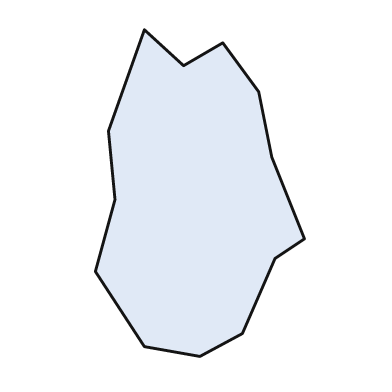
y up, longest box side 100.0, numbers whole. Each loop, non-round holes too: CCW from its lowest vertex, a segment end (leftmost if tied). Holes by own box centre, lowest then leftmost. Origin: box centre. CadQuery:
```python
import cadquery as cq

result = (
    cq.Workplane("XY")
    .moveTo(0.0, -50.0)
    .lineTo(13.0, -43.0)
    .lineTo(23.0, -20.0)
    .lineTo(32.0, -14.0)
    .lineTo(22.0, 11.0)
    .lineTo(18.0, 31.0)
    .lineTo(7.0, 46.0)
    .lineTo(-5.0, 39.0)
    .lineTo(-17.0, 50.0)
    .lineTo(-28.0, 19.0)
    .lineTo(-26.0, -2.0)
    .lineTo(-32.0, -24.0)
    .lineTo(-17.0, -47.0)
    .close()
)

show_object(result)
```